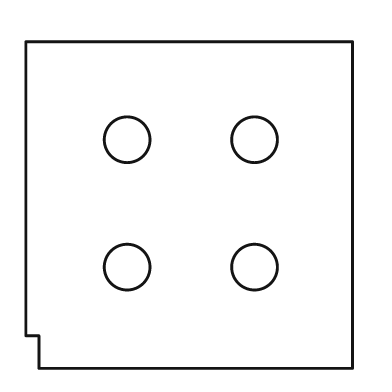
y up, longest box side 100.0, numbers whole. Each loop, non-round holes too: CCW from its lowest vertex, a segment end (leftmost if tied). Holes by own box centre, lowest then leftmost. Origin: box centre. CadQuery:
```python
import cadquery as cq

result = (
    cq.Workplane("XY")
    .moveTo(-46.0, -50.0)
    .lineTo(50.0, -50.0)
    .lineTo(50.0, 50.0)
    .lineTo(-50.0, 50.0)
    .lineTo(-50.0, -40.0)
    .lineTo(-46.0, -40.0)
    .close()
    .moveTo(-19.0, -19.0)
    .circle(7.0)
    .moveTo(20.0, -19.0)
    .circle(7.0)
    .moveTo(-19.0, 20.0)
    .circle(7.0)
    .moveTo(20.0, 20.0)
    .circle(7.0)
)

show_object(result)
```